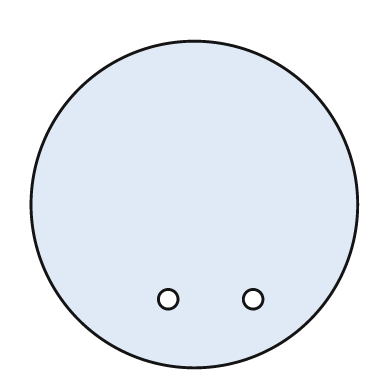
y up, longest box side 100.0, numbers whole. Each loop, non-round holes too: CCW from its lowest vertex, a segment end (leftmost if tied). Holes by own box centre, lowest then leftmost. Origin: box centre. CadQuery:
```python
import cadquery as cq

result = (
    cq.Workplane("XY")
    .moveTo(0.0, 0.0)
    .circle(50.0)
    .moveTo(-8.0, -29.0)
    .circle(3.0)
    .moveTo(18.0, -29.0)
    .circle(3.0)
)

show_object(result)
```